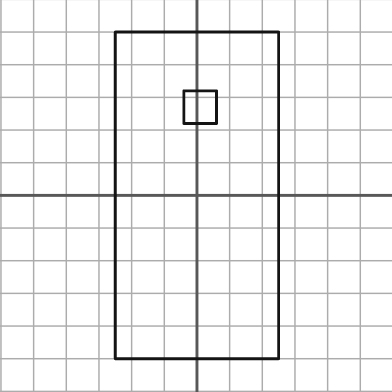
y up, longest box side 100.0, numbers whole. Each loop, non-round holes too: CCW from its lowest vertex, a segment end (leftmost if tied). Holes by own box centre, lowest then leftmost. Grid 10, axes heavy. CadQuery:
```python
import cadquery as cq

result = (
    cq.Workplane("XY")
    .moveTo(-25.0, -50.0)
    .lineTo(25.0, -50.0)
    .lineTo(25.0, 50.0)
    .lineTo(-25.0, 50.0)
    .close()
    .moveTo(-4.0, 22.0)
    .lineTo(6.0, 22.0)
    .lineTo(6.0, 32.0)
    .lineTo(-4.0, 32.0)
    .close()
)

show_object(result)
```